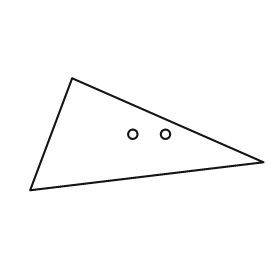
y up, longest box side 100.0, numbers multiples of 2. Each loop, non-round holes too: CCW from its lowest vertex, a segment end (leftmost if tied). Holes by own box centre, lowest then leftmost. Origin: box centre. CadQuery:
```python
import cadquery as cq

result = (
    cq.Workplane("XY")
    .moveTo(-50.0, -24.0)
    .lineTo(50.0, -12.0)
    .lineTo(-32.0, 24.0)
    .close()
    .moveTo(-6.0, 0.0)
    .circle(2.0)
    .moveTo(8.0, 0.0)
    .circle(2.0)
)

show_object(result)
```